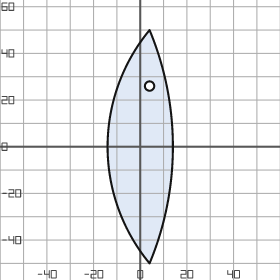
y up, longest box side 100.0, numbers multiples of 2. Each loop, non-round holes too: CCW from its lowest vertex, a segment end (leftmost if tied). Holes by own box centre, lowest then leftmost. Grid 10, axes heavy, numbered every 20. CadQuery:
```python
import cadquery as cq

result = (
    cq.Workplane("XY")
    .moveTo(4.0, -50.0)
    .threePointArc((14.0, 0.0), (4.0, 50.0))
    .threePointArc((-14.0, 0.0), (4.0, -50.0))
    .close()
    .moveTo(4.0, 26.0)
    .circle(2.0)
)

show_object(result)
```